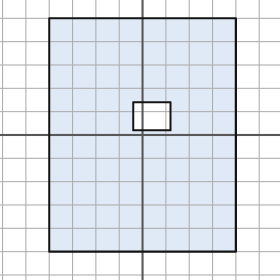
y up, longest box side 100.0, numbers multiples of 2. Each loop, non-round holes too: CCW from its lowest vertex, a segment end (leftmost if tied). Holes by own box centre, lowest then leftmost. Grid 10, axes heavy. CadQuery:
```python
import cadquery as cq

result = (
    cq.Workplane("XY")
    .moveTo(-40.0, -50.0)
    .lineTo(40.0, -50.0)
    .lineTo(40.0, 50.0)
    .lineTo(-40.0, 50.0)
    .close()
    .moveTo(-4.0, 2.0)
    .lineTo(12.0, 2.0)
    .lineTo(12.0, 14.0)
    .lineTo(-4.0, 14.0)
    .close()
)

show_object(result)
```